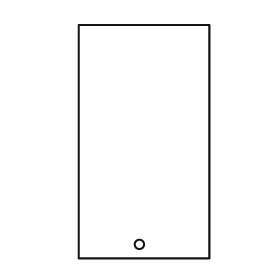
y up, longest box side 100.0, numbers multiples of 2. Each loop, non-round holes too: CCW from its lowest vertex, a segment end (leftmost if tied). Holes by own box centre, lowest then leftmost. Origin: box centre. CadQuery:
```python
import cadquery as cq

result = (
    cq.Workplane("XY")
    .moveTo(-28.0, -50.0)
    .lineTo(28.0, -50.0)
    .lineTo(28.0, 50.0)
    .lineTo(-28.0, 50.0)
    .close()
    .moveTo(-2.0, -44.0)
    .circle(2.0)
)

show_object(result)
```